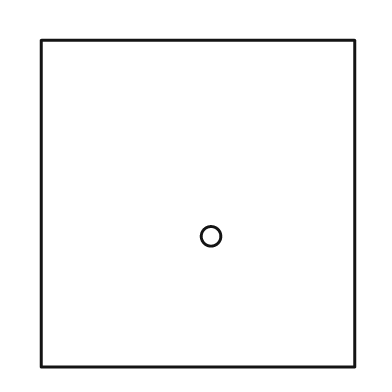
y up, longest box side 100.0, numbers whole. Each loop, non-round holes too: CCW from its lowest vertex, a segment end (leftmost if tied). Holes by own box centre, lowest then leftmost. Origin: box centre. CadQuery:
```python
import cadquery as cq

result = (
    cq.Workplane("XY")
    .moveTo(-48.0, -50.0)
    .lineTo(48.0, -50.0)
    .lineTo(48.0, 50.0)
    .lineTo(-48.0, 50.0)
    .close()
    .moveTo(4.0, -10.0)
    .circle(3.0)
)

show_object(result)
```